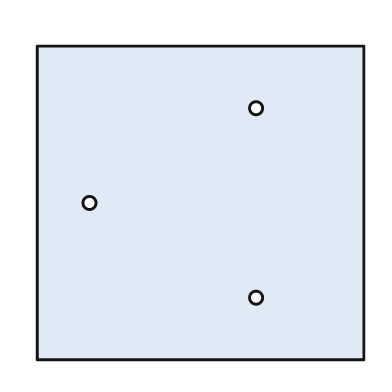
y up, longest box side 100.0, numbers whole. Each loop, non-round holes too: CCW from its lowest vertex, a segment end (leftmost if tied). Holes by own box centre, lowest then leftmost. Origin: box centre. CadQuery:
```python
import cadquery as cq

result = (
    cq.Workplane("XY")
    .moveTo(-50.0, -48.0)
    .lineTo(50.0, -48.0)
    .lineTo(50.0, 48.0)
    .lineTo(-50.0, 48.0)
    .close()
    .moveTo(17.0, -29.0)
    .circle(2.0)
    .moveTo(-34.0, 0.0)
    .circle(2.0)
    .moveTo(17.0, 29.0)
    .circle(2.0)
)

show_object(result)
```